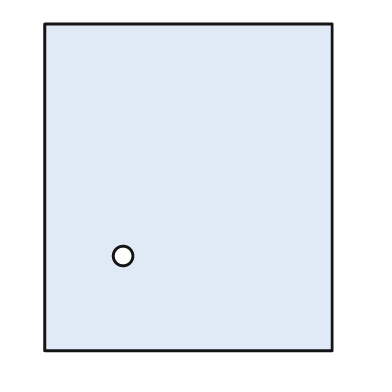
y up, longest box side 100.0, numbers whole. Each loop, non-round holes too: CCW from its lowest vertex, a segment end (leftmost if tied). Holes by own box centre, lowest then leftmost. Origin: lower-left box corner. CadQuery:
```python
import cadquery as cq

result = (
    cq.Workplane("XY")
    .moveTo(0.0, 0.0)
    .lineTo(88.0, 0.0)
    .lineTo(88.0, 100.0)
    .lineTo(0.0, 100.0)
    .close()
    .moveTo(24.0, 29.0)
    .circle(3.0)
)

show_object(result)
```